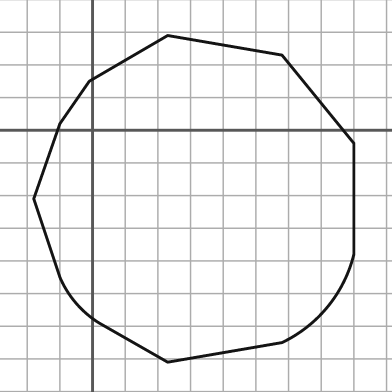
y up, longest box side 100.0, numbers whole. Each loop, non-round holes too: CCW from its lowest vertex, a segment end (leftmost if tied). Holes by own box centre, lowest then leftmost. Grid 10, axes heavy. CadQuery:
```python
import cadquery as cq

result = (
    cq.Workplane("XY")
    .moveTo(23.0, -71.0)
    .lineTo(58.0, -65.0)
    .threePointArc((72.0, -54.0), (80.0, -38.0))
    .lineTo(80.0, -4.0)
    .lineTo(58.0, 23.0)
    .lineTo(23.0, 29.0)
    .lineTo(-1.0, 15.0)
    .lineTo(-10.0, 2.0)
    .lineTo(-18.0, -21.0)
    .lineTo(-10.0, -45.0)
    .threePointArc((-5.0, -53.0), (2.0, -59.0))
    .close()
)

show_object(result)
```